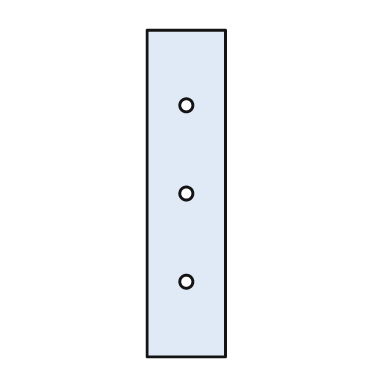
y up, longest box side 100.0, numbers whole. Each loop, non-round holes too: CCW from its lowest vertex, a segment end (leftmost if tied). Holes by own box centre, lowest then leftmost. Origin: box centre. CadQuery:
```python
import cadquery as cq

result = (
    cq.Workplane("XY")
    .moveTo(-12.0, -50.0)
    .lineTo(12.0, -50.0)
    .lineTo(12.0, 50.0)
    .lineTo(-12.0, 50.0)
    .close()
    .moveTo(0.0, -27.0)
    .circle(2.0)
    .moveTo(0.0, 0.0)
    .circle(2.0)
    .moveTo(0.0, 27.0)
    .circle(2.0)
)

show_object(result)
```